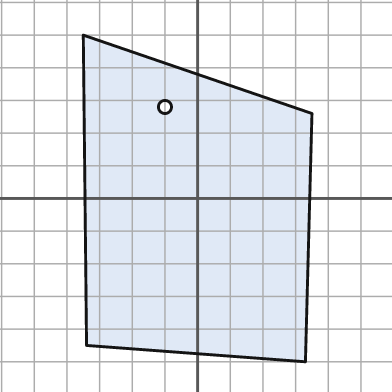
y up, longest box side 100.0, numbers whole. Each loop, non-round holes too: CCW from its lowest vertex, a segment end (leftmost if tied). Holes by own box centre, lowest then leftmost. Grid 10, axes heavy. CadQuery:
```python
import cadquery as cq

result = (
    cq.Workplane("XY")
    .moveTo(33.0, -50.0)
    .lineTo(35.0, 26.0)
    .lineTo(-35.0, 50.0)
    .lineTo(-34.0, -45.0)
    .close()
    .moveTo(-10.0, 28.0)
    .circle(2.0)
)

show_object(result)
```